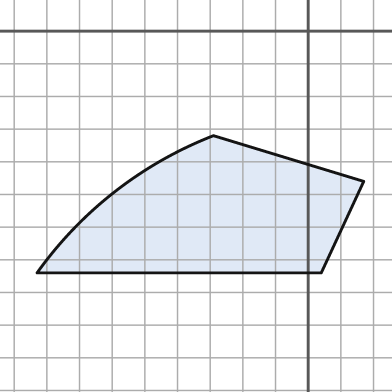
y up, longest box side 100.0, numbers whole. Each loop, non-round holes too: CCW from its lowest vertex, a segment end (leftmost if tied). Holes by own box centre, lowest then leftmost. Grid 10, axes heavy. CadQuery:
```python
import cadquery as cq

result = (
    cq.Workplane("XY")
    .moveTo(-83.0, -74.0)
    .lineTo(4.0, -74.0)
    .lineTo(17.0, -46.0)
    .lineTo(-29.0, -32.0)
    .threePointArc((-59.0, -49.0), (-83.0, -74.0))
    .close()
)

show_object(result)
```